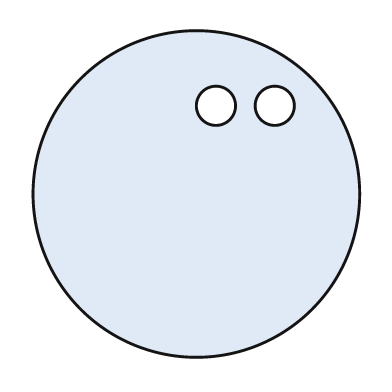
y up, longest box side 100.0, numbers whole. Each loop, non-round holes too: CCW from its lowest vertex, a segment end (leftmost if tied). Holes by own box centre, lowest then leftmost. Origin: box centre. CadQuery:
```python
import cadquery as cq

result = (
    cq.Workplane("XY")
    .moveTo(0.0, 0.0)
    .circle(50.0)
    .moveTo(6.0, 27.0)
    .circle(6.0)
    .moveTo(24.0, 27.0)
    .circle(6.0)
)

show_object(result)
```